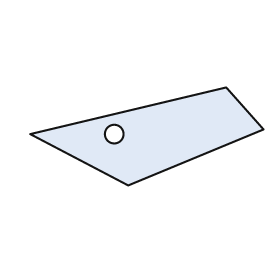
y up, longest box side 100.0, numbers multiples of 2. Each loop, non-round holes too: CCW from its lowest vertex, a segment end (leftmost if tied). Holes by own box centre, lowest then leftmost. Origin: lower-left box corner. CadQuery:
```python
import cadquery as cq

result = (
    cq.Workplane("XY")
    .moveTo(42.0, 0.0)
    .lineTo(100.0, 24.0)
    .lineTo(84.0, 42.0)
    .lineTo(0.0, 22.0)
    .close()
    .moveTo(36.0, 22.0)
    .circle(4.0)
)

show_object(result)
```